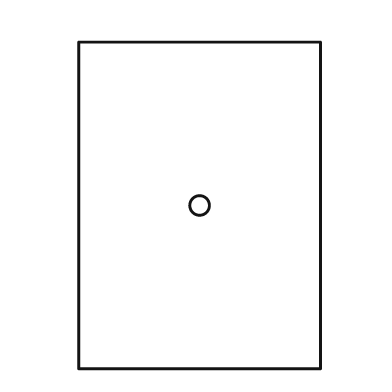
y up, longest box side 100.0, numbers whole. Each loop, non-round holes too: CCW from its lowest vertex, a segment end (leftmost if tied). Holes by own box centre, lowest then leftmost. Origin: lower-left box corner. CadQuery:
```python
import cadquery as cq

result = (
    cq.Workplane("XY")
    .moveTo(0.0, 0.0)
    .lineTo(74.0, 0.0)
    .lineTo(74.0, 100.0)
    .lineTo(0.0, 100.0)
    .close()
    .moveTo(37.0, 50.0)
    .circle(3.0)
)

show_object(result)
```